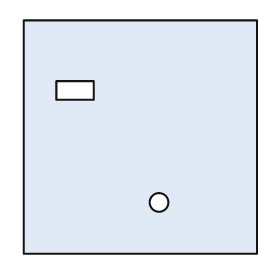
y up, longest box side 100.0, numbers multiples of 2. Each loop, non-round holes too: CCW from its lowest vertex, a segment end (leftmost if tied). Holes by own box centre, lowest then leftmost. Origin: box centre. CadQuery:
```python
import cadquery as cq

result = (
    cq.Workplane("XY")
    .moveTo(-50.0, -50.0)
    .lineTo(50.0, -50.0)
    .lineTo(50.0, 50.0)
    .lineTo(-50.0, 50.0)
    .close()
    .moveTo(8.0, -28.0)
    .circle(4.0)
    .moveTo(-36.0, 16.0)
    .lineTo(-20.0, 16.0)
    .lineTo(-20.0, 24.0)
    .lineTo(-36.0, 24.0)
    .close()
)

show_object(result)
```